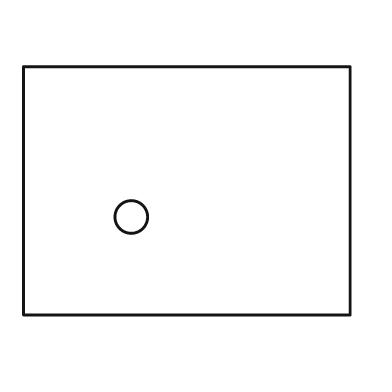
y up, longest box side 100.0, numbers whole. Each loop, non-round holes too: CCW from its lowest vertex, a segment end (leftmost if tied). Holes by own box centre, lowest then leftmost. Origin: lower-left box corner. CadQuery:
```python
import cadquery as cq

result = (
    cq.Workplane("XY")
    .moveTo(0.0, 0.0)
    .lineTo(100.0, 0.0)
    .lineTo(100.0, 76.0)
    .lineTo(0.0, 76.0)
    .close()
    .moveTo(33.0, 30.0)
    .circle(5.0)
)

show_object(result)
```